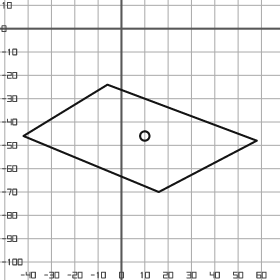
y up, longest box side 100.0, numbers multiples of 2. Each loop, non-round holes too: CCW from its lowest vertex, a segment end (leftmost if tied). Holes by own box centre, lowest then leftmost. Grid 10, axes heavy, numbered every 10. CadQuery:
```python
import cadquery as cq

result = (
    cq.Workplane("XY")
    .moveTo(16.0, -70.0)
    .lineTo(58.0, -48.0)
    .lineTo(-6.0, -24.0)
    .lineTo(-42.0, -46.0)
    .close()
    .moveTo(10.0, -46.0)
    .circle(2.0)
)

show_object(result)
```